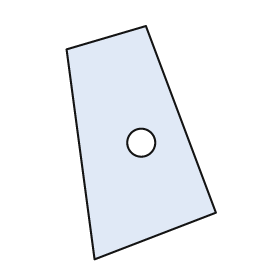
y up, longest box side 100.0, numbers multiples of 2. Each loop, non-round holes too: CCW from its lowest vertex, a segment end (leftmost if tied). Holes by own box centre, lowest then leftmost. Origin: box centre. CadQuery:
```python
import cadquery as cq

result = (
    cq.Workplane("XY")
    .moveTo(-20.0, -50.0)
    .lineTo(32.0, -30.0)
    .lineTo(2.0, 50.0)
    .lineTo(-32.0, 40.0)
    .close()
    .moveTo(0.0, 0.0)
    .circle(6.0)
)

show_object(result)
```